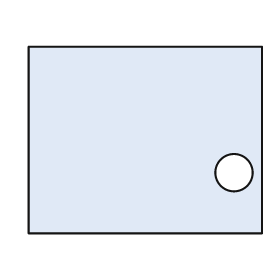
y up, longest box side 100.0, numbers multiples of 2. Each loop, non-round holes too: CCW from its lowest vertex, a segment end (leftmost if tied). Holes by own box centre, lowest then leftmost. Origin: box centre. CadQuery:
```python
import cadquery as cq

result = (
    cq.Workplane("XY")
    .moveTo(-50.0, -40.0)
    .lineTo(50.0, -40.0)
    .lineTo(50.0, 40.0)
    .lineTo(-50.0, 40.0)
    .close()
    .moveTo(38.0, -14.0)
    .circle(8.0)
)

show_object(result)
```